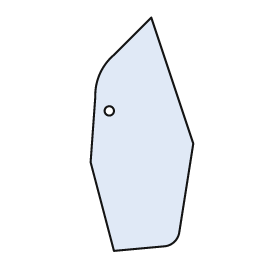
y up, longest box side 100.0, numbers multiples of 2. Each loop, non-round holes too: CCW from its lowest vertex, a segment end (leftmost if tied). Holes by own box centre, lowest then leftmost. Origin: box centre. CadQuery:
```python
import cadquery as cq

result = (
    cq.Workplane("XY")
    .moveTo(-12.0, -50.0)
    .lineTo(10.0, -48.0)
    .threePointArc((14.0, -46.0), (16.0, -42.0))
    .lineTo(22.0, -4.0)
    .lineTo(4.0, 50.0)
    .lineTo(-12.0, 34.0)
    .threePointArc((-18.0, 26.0), (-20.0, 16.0))
    .lineTo(-22.0, -12.0)
    .close()
    .moveTo(-14.0, 10.0)
    .circle(2.0)
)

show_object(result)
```